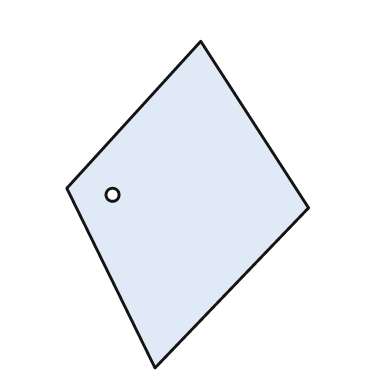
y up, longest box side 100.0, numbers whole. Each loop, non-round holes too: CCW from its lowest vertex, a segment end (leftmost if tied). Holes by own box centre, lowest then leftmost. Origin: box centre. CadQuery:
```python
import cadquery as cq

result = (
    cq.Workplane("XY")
    .moveTo(-10.0, -50.0)
    .lineTo(37.0, -1.0)
    .lineTo(4.0, 50.0)
    .lineTo(-37.0, 5.0)
    .close()
    .moveTo(-23.0, 3.0)
    .circle(2.0)
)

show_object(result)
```